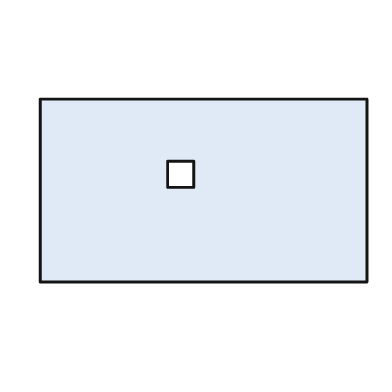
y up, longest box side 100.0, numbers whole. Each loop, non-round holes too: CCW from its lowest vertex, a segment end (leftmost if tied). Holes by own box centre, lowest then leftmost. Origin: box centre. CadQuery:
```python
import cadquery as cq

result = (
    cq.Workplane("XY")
    .moveTo(-50.0, -28.0)
    .lineTo(50.0, -28.0)
    .lineTo(50.0, 28.0)
    .lineTo(-50.0, 28.0)
    .close()
    .moveTo(-11.0, 1.0)
    .lineTo(-3.0, 1.0)
    .lineTo(-3.0, 9.0)
    .lineTo(-11.0, 9.0)
    .close()
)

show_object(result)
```